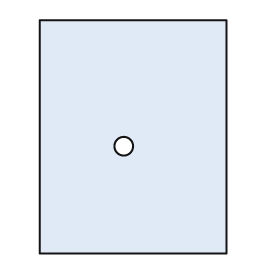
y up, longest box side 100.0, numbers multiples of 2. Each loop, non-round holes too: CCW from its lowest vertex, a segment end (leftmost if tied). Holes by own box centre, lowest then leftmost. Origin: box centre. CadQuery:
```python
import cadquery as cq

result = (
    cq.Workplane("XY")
    .moveTo(-40.0, -50.0)
    .lineTo(40.0, -50.0)
    .lineTo(40.0, 50.0)
    .lineTo(-40.0, 50.0)
    .close()
    .moveTo(-4.0, -4.0)
    .circle(4.0)
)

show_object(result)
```